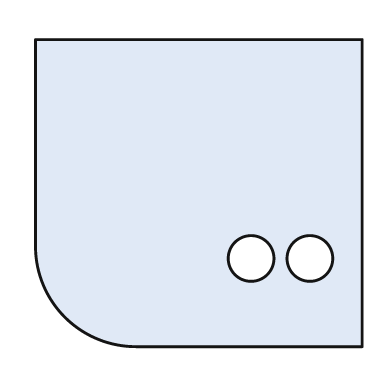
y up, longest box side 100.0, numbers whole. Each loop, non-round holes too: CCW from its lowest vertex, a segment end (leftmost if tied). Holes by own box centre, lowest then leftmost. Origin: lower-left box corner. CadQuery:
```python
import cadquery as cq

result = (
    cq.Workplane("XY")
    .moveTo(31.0, 0.0)
    .lineTo(100.0, 0.0)
    .lineTo(100.0, 94.0)
    .lineTo(0.0, 94.0)
    .lineTo(0.0, 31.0)
    .threePointArc((9.0, 9.0), (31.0, 0.0))
    .close()
    .moveTo(66.0, 27.0)
    .circle(7.0)
    .moveTo(84.0, 27.0)
    .circle(7.0)
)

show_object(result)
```